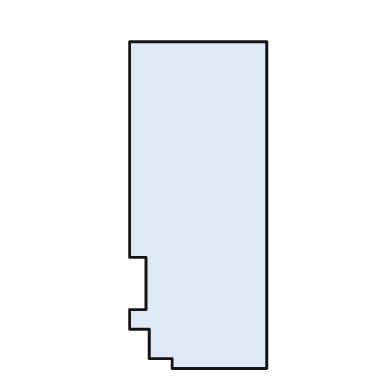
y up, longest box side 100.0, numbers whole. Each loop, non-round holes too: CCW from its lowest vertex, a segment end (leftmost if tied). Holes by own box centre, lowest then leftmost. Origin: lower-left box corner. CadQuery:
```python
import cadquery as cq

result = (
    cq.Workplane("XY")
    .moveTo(13.0, 0.0)
    .lineTo(42.0, 0.0)
    .lineTo(42.0, 100.0)
    .lineTo(0.0, 100.0)
    .lineTo(0.0, 34.0)
    .lineTo(5.0, 34.0)
    .lineTo(5.0, 18.0)
    .lineTo(0.0, 18.0)
    .lineTo(0.0, 12.0)
    .lineTo(6.0, 12.0)
    .lineTo(6.0, 3.0)
    .lineTo(13.0, 3.0)
    .close()
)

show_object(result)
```